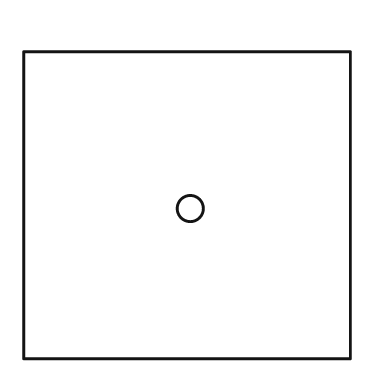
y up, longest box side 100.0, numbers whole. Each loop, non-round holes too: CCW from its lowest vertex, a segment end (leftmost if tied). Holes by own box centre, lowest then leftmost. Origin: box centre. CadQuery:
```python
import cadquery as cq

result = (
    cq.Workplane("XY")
    .moveTo(-50.0, -47.0)
    .lineTo(50.0, -47.0)
    .lineTo(50.0, 47.0)
    .lineTo(-50.0, 47.0)
    .close()
    .moveTo(1.0, -1.0)
    .circle(4.0)
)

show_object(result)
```